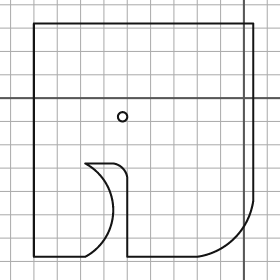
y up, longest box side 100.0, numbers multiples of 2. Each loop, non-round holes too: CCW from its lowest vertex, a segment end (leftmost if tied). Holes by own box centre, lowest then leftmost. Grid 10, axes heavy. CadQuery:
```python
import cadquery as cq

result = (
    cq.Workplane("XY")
    .moveTo(-90.0, -68.0)
    .lineTo(-68.0, -68.0)
    .threePointArc((-56.0, -48.0), (-68.0, -28.0))
    .lineTo(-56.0, -28.0)
    .threePointArc((-52.0, -30.0), (-50.0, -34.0))
    .lineTo(-50.0, -68.0)
    .lineTo(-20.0, -68.0)
    .threePointArc((-4.0, -60.0), (4.0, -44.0))
    .lineTo(4.0, 32.0)
    .lineTo(-90.0, 32.0)
    .close()
    .moveTo(-52.0, -8.0)
    .circle(2.0)
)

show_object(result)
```